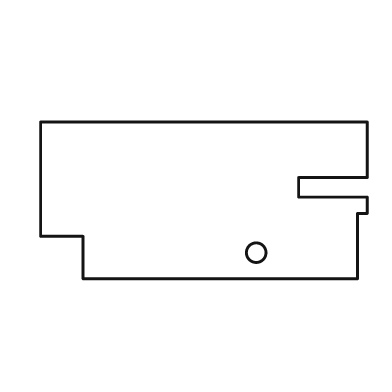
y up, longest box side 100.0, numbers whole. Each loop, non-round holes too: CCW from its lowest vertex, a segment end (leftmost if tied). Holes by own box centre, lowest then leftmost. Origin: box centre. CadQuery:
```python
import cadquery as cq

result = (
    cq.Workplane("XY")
    .moveTo(-37.0, -24.0)
    .lineTo(47.0, -24.0)
    .lineTo(47.0, -4.0)
    .lineTo(50.0, -4.0)
    .lineTo(50.0, 1.0)
    .lineTo(29.0, 1.0)
    .lineTo(29.0, 7.0)
    .lineTo(50.0, 7.0)
    .lineTo(50.0, 24.0)
    .lineTo(-50.0, 24.0)
    .lineTo(-50.0, -11.0)
    .lineTo(-37.0, -11.0)
    .close()
    .moveTo(16.0, -16.0)
    .circle(3.0)
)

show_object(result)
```